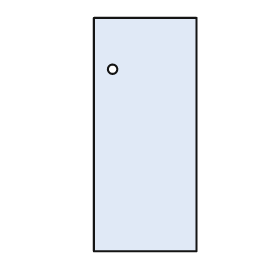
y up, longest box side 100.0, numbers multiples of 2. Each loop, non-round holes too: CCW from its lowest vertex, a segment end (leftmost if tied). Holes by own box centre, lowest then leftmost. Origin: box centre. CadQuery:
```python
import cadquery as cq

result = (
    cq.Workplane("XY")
    .moveTo(-22.0, -50.0)
    .lineTo(22.0, -50.0)
    .lineTo(22.0, 50.0)
    .lineTo(-22.0, 50.0)
    .close()
    .moveTo(-14.0, 28.0)
    .circle(2.0)
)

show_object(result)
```